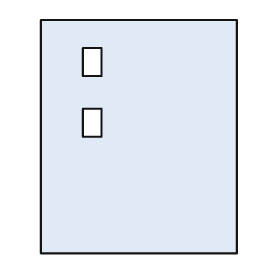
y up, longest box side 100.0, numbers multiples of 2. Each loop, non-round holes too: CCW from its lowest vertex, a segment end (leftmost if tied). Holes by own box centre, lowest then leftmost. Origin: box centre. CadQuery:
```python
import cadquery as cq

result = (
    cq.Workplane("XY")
    .moveTo(-42.0, -50.0)
    .lineTo(42.0, -50.0)
    .lineTo(42.0, 50.0)
    .lineTo(-42.0, 50.0)
    .close()
    .moveTo(-24.0, 0.0)
    .lineTo(-16.0, 0.0)
    .lineTo(-16.0, 12.0)
    .lineTo(-24.0, 12.0)
    .close()
    .moveTo(-24.0, 26.0)
    .lineTo(-16.0, 26.0)
    .lineTo(-16.0, 38.0)
    .lineTo(-24.0, 38.0)
    .close()
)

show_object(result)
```